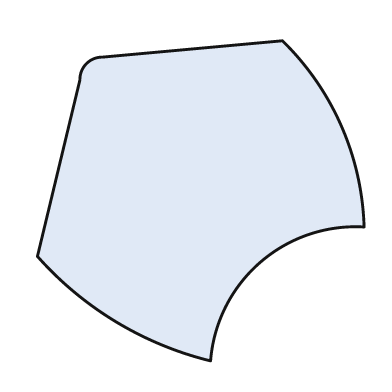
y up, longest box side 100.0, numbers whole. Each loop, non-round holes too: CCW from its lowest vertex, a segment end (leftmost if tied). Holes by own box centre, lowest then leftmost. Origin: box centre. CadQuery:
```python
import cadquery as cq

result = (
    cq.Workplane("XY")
    .moveTo(3.0, -49.0)
    .threePointArc((18.0, -19.0), (50.0, -8.0))
    .threePointArc((43.0, 23.0), (25.0, 49.0))
    .lineTo(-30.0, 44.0)
    .threePointArc((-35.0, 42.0), (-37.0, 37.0))
    .lineTo(-50.0, -17.0)
    .threePointArc((-26.0, -37.0), (3.0, -49.0))
    .close()
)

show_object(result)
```